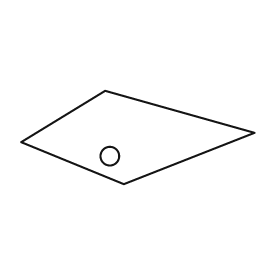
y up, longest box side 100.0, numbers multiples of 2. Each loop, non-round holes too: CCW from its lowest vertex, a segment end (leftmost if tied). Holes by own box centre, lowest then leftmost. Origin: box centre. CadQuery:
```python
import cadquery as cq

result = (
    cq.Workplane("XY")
    .moveTo(-6.0, -20.0)
    .lineTo(50.0, 2.0)
    .lineTo(-14.0, 20.0)
    .lineTo(-50.0, -2.0)
    .close()
    .moveTo(-12.0, -8.0)
    .circle(4.0)
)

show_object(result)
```